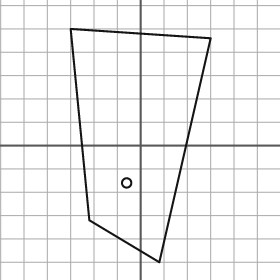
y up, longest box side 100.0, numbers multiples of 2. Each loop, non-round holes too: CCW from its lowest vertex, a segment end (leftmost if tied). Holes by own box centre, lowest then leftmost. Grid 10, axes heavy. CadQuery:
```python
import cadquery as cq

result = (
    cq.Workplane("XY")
    .moveTo(8.0, -50.0)
    .lineTo(30.0, 46.0)
    .lineTo(-30.0, 50.0)
    .lineTo(-22.0, -32.0)
    .close()
    .moveTo(-6.0, -16.0)
    .circle(2.0)
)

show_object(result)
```